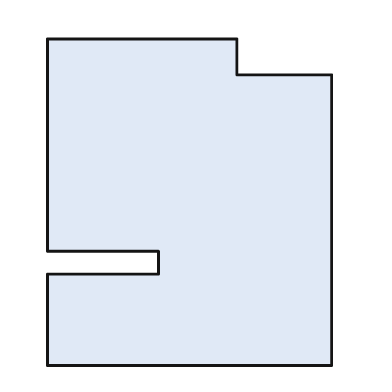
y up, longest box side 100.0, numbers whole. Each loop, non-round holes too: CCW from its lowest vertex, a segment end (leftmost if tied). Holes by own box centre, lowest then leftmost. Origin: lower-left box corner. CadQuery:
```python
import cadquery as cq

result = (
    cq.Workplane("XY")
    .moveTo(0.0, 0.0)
    .lineTo(87.0, 0.0)
    .lineTo(87.0, 89.0)
    .lineTo(58.0, 89.0)
    .lineTo(58.0, 100.0)
    .lineTo(0.0, 100.0)
    .lineTo(0.0, 35.0)
    .lineTo(34.0, 35.0)
    .lineTo(34.0, 28.0)
    .lineTo(0.0, 28.0)
    .close()
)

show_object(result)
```